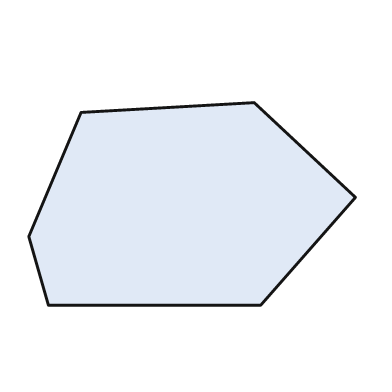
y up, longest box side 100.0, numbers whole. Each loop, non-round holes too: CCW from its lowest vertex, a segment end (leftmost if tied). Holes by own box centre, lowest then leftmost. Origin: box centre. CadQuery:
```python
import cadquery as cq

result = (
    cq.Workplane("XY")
    .moveTo(-44.0, -31.0)
    .lineTo(21.0, -31.0)
    .lineTo(50.0, 2.0)
    .lineTo(19.0, 31.0)
    .lineTo(-34.0, 28.0)
    .lineTo(-50.0, -10.0)
    .close()
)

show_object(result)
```